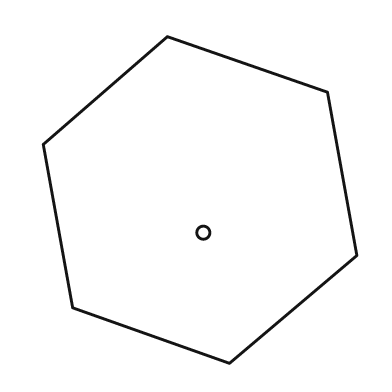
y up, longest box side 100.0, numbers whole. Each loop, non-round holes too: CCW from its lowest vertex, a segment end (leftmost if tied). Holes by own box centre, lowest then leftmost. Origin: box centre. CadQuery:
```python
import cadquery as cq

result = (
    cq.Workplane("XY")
    .moveTo(9.0, -50.0)
    .lineTo(48.0, -17.0)
    .lineTo(39.0, 33.0)
    .lineTo(-10.0, 50.0)
    .lineTo(-48.0, 17.0)
    .lineTo(-39.0, -33.0)
    .close()
    .moveTo(1.0, -10.0)
    .circle(2.0)
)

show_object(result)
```